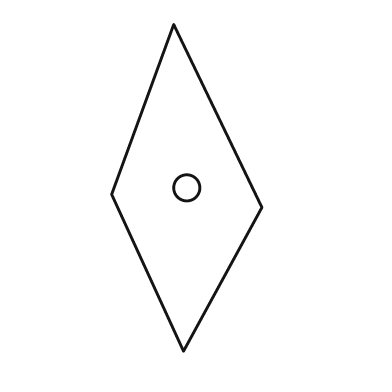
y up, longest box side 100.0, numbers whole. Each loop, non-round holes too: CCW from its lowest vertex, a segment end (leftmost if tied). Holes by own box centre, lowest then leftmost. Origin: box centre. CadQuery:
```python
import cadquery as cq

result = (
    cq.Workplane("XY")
    .moveTo(-1.0, -50.0)
    .lineTo(23.0, -6.0)
    .lineTo(-4.0, 50.0)
    .lineTo(-23.0, -2.0)
    .close()
    .moveTo(0.0, 0.0)
    .circle(4.0)
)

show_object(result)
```